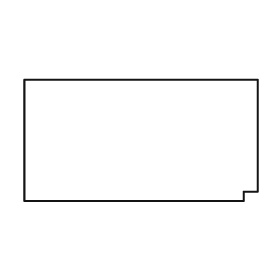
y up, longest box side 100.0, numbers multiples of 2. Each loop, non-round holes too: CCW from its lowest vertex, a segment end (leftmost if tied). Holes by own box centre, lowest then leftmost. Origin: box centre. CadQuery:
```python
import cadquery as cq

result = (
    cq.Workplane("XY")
    .moveTo(-50.0, -26.0)
    .lineTo(44.0, -26.0)
    .lineTo(44.0, -22.0)
    .lineTo(50.0, -22.0)
    .lineTo(50.0, 26.0)
    .lineTo(-50.0, 26.0)
    .close()
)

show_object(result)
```